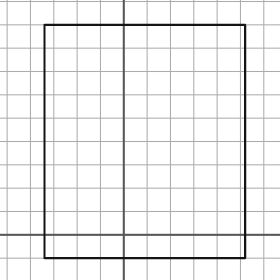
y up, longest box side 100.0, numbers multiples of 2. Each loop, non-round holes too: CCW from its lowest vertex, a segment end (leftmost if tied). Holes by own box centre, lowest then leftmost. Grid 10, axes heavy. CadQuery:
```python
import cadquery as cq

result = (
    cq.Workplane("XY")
    .moveTo(-34.0, -10.0)
    .lineTo(52.0, -10.0)
    .lineTo(52.0, 90.0)
    .lineTo(-34.0, 90.0)
    .close()
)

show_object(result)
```